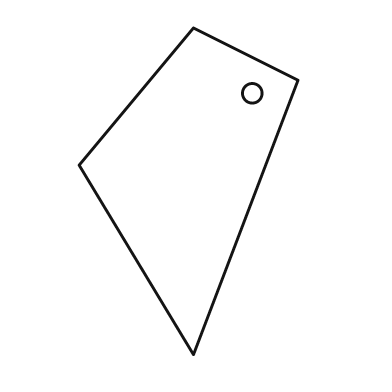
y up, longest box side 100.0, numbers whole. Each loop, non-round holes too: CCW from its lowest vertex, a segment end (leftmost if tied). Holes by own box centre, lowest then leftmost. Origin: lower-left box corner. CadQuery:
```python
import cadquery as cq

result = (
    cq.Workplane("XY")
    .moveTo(35.0, 0.0)
    .lineTo(67.0, 84.0)
    .lineTo(35.0, 100.0)
    .lineTo(0.0, 58.0)
    .close()
    .moveTo(53.0, 80.0)
    .circle(3.0)
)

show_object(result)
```